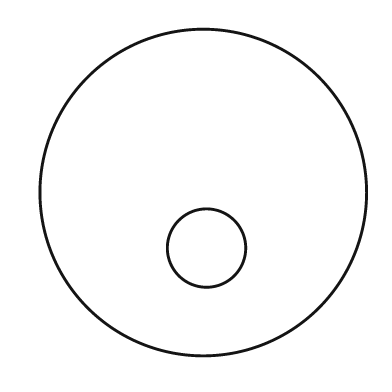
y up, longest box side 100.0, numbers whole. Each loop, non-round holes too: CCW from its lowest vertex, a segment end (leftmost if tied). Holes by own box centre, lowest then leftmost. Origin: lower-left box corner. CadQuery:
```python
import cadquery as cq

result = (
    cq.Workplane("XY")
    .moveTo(50.0, 50.0)
    .circle(50.0)
    .moveTo(51.0, 33.0)
    .circle(12.0)
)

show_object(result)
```